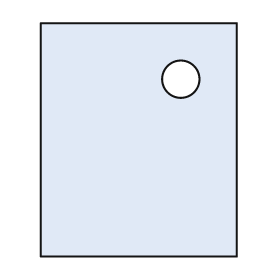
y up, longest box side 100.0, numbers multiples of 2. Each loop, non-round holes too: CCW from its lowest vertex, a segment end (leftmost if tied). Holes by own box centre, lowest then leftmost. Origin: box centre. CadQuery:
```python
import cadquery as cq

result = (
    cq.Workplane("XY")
    .moveTo(-42.0, -50.0)
    .lineTo(42.0, -50.0)
    .lineTo(42.0, 50.0)
    .lineTo(-42.0, 50.0)
    .close()
    .moveTo(18.0, 26.0)
    .circle(8.0)
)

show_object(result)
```